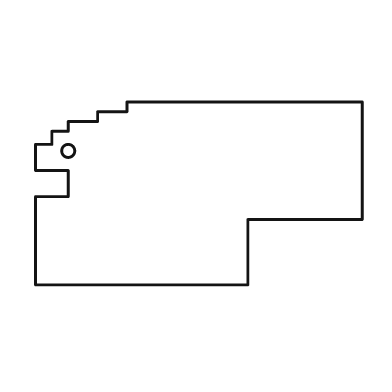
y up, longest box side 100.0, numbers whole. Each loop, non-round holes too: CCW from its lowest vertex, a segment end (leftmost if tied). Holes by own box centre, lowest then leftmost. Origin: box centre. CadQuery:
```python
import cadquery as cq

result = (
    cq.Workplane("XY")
    .moveTo(-50.0, -28.0)
    .lineTo(15.0, -28.0)
    .lineTo(15.0, -8.0)
    .lineTo(50.0, -8.0)
    .lineTo(50.0, 28.0)
    .lineTo(-22.0, 28.0)
    .lineTo(-22.0, 25.0)
    .lineTo(-31.0, 25.0)
    .lineTo(-31.0, 22.0)
    .lineTo(-40.0, 22.0)
    .lineTo(-40.0, 19.0)
    .lineTo(-45.0, 19.0)
    .lineTo(-45.0, 15.0)
    .lineTo(-50.0, 15.0)
    .lineTo(-50.0, 7.0)
    .lineTo(-40.0, 7.0)
    .lineTo(-40.0, -1.0)
    .lineTo(-50.0, -1.0)
    .close()
    .moveTo(-40.0, 13.0)
    .circle(2.0)
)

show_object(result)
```